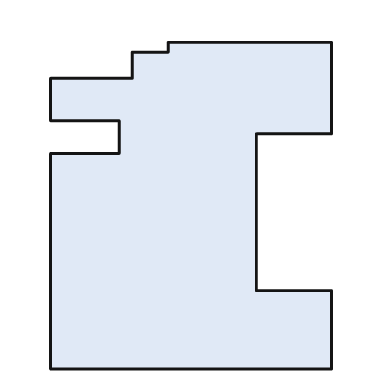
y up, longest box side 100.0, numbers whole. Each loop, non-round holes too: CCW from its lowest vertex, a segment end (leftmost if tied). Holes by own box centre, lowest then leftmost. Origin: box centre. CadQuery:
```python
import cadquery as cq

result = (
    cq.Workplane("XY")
    .moveTo(-43.0, -50.0)
    .lineTo(43.0, -50.0)
    .lineTo(43.0, -26.0)
    .lineTo(20.0, -26.0)
    .lineTo(20.0, 22.0)
    .lineTo(43.0, 22.0)
    .lineTo(43.0, 50.0)
    .lineTo(-7.0, 50.0)
    .lineTo(-7.0, 47.0)
    .lineTo(-18.0, 47.0)
    .lineTo(-18.0, 39.0)
    .lineTo(-43.0, 39.0)
    .lineTo(-43.0, 26.0)
    .lineTo(-22.0, 26.0)
    .lineTo(-22.0, 16.0)
    .lineTo(-43.0, 16.0)
    .close()
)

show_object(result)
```